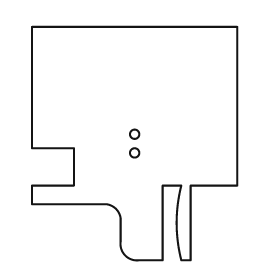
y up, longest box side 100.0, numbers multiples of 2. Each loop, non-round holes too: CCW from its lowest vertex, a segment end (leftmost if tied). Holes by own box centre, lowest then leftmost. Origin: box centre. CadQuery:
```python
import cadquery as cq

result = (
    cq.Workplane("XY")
    .moveTo(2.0, -50.0)
    .lineTo(12.0, -50.0)
    .lineTo(12.0, -18.0)
    .lineTo(20.0, -18.0)
    .threePointArc((18.0, -34.0), (20.0, -50.0))
    .lineTo(24.0, -50.0)
    .lineTo(24.0, -18.0)
    .lineTo(44.0, -18.0)
    .lineTo(44.0, 50.0)
    .lineTo(-44.0, 50.0)
    .lineTo(-44.0, -2.0)
    .lineTo(-26.0, -2.0)
    .lineTo(-26.0, -18.0)
    .lineTo(-44.0, -18.0)
    .lineTo(-44.0, -26.0)
    .lineTo(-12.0, -26.0)
    .threePointArc((-8.0, -28.0), (-6.0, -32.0))
    .lineTo(-6.0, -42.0)
    .threePointArc((-4.0, -48.0), (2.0, -50.0))
    .close()
    .moveTo(0.0, -4.0)
    .circle(2.0)
    .moveTo(0.0, 4.0)
    .circle(2.0)
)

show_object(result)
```